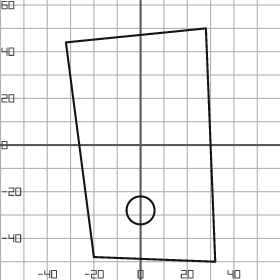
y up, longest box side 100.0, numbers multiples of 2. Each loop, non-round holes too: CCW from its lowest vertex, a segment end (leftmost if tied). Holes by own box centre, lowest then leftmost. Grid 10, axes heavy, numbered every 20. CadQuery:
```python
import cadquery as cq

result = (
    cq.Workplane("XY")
    .moveTo(32.0, -50.0)
    .lineTo(28.0, 50.0)
    .lineTo(-32.0, 44.0)
    .lineTo(-20.0, -48.0)
    .close()
    .moveTo(0.0, -28.0)
    .circle(6.0)
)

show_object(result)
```